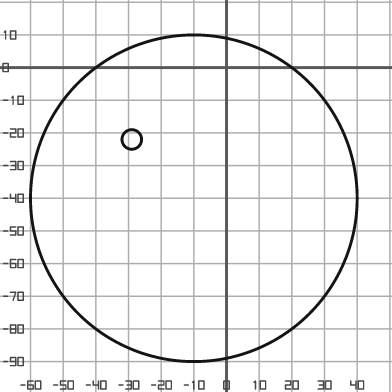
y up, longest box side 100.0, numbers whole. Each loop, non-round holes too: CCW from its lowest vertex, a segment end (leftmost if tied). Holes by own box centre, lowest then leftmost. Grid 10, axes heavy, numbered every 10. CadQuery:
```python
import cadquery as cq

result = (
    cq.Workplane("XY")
    .moveTo(-10.0, -40.0)
    .circle(50.0)
    .moveTo(-29.0, -22.0)
    .circle(3.0)
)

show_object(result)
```